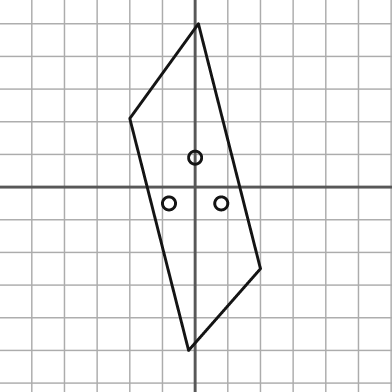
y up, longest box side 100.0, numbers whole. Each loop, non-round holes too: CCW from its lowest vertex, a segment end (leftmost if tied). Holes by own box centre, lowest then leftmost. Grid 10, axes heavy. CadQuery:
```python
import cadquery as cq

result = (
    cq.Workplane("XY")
    .moveTo(-2.0, -50.0)
    .lineTo(20.0, -25.0)
    .lineTo(1.0, 50.0)
    .lineTo(-20.0, 21.0)
    .close()
    .moveTo(-8.0, -5.0)
    .circle(2.0)
    .moveTo(8.0, -5.0)
    .circle(2.0)
    .moveTo(0.0, 9.0)
    .circle(2.0)
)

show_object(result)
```